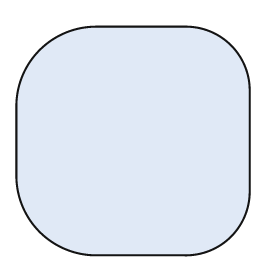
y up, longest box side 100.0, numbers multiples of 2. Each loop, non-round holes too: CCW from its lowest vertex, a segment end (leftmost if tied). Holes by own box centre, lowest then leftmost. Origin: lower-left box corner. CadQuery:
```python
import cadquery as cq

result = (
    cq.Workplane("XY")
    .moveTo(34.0, 0.0)
    .lineTo(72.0, 0.0)
    .threePointArc((92.0, 8.0), (100.0, 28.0))
    .lineTo(100.0, 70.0)
    .threePointArc((92.0, 90.0), (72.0, 98.0))
    .lineTo(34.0, 98.0)
    .threePointArc((10.0, 88.0), (0.0, 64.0))
    .lineTo(0.0, 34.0)
    .threePointArc((10.0, 10.0), (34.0, 0.0))
    .close()
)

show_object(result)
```